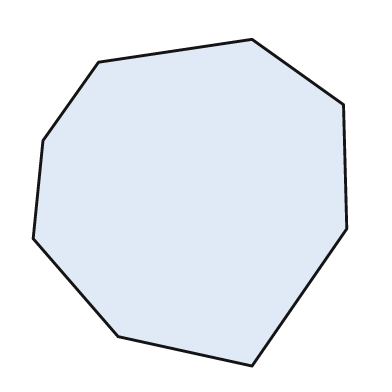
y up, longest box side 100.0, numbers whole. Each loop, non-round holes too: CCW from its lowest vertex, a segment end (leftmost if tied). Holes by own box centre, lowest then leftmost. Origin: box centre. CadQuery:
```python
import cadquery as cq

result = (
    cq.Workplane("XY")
    .moveTo(19.0, -50.0)
    .lineTo(48.0, -8.0)
    .lineTo(47.0, 30.0)
    .lineTo(19.0, 50.0)
    .lineTo(-28.0, 43.0)
    .lineTo(-45.0, 19.0)
    .lineTo(-48.0, -11.0)
    .lineTo(-22.0, -41.0)
    .close()
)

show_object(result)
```